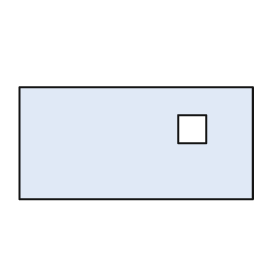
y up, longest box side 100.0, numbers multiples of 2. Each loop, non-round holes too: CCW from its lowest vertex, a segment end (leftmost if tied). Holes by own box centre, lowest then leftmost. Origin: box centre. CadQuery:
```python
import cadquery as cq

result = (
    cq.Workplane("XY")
    .moveTo(-50.0, -24.0)
    .lineTo(50.0, -24.0)
    .lineTo(50.0, 24.0)
    .lineTo(-50.0, 24.0)
    .close()
    .moveTo(18.0, 0.0)
    .lineTo(30.0, 0.0)
    .lineTo(30.0, 12.0)
    .lineTo(18.0, 12.0)
    .close()
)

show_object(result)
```